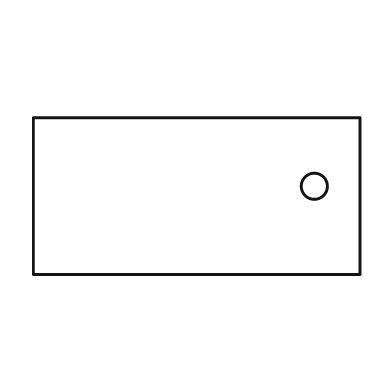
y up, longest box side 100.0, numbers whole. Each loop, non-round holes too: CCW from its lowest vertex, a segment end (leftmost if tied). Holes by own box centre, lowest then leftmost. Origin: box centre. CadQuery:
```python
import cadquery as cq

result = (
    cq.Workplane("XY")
    .moveTo(-50.0, -24.0)
    .lineTo(50.0, -24.0)
    .lineTo(50.0, 24.0)
    .lineTo(-50.0, 24.0)
    .close()
    .moveTo(36.0, 3.0)
    .circle(4.0)
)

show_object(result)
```